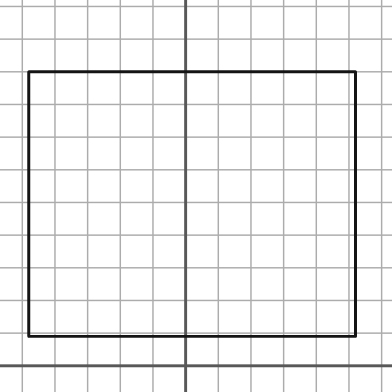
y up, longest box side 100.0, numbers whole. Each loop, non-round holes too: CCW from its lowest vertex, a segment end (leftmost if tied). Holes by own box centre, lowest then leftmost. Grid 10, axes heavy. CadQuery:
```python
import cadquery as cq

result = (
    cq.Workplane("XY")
    .moveTo(-48.0, 9.0)
    .lineTo(52.0, 9.0)
    .lineTo(52.0, 90.0)
    .lineTo(-48.0, 90.0)
    .close()
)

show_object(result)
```